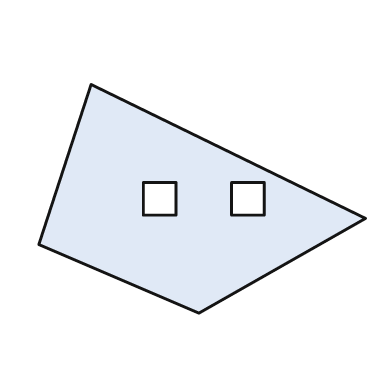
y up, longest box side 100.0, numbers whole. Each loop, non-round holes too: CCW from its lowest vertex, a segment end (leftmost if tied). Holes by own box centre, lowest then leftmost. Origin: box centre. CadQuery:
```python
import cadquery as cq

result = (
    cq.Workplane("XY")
    .moveTo(-1.0, -35.0)
    .lineTo(50.0, -6.0)
    .lineTo(-34.0, 35.0)
    .lineTo(-50.0, -14.0)
    .close()
    .moveTo(-18.0, -5.0)
    .lineTo(-8.0, -5.0)
    .lineTo(-8.0, 5.0)
    .lineTo(-18.0, 5.0)
    .close()
    .moveTo(9.0, -5.0)
    .lineTo(19.0, -5.0)
    .lineTo(19.0, 5.0)
    .lineTo(9.0, 5.0)
    .close()
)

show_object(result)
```